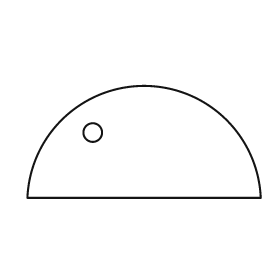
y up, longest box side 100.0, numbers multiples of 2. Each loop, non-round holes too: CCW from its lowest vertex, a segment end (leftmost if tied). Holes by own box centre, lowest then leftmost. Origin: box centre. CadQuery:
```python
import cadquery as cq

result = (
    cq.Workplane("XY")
    .moveTo(-50.0, -24.0)
    .lineTo(50.0, -24.0)
    .threePointArc((0.0, 24.0), (-50.0, -24.0))
    .close()
    .moveTo(-22.0, 4.0)
    .circle(4.0)
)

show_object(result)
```